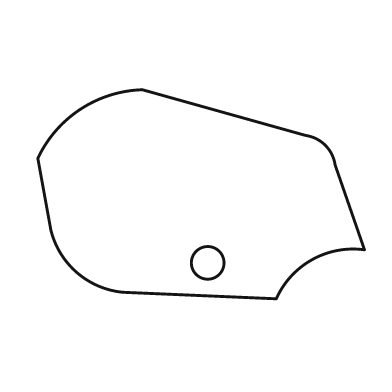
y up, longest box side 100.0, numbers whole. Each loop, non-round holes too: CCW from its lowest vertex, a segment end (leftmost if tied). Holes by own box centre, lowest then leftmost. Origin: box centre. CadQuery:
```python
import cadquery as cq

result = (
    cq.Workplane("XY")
    .moveTo(23.0, -32.0)
    .threePointArc((34.0, -20.0), (50.0, -17.0))
    .lineTo(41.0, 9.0)
    .threePointArc((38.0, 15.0), (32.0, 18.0))
    .lineTo(-18.0, 32.0)
    .threePointArc((-37.0, 26.0), (-50.0, 11.0))
    .lineTo(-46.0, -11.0)
    .threePointArc((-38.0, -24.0), (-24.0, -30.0))
    .close()
    .moveTo(2.0, -21.0)
    .circle(5.0)
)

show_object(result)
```